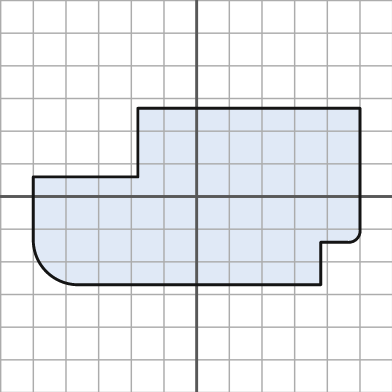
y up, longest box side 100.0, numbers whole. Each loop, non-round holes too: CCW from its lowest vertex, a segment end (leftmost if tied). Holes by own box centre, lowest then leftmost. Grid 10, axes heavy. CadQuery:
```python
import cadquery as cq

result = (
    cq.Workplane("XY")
    .moveTo(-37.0, -27.0)
    .lineTo(38.0, -27.0)
    .lineTo(38.0, -14.0)
    .lineTo(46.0, -14.0)
    .threePointArc((49.0, -13.0), (50.0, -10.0))
    .lineTo(50.0, 27.0)
    .lineTo(-18.0, 27.0)
    .lineTo(-18.0, 6.0)
    .lineTo(-50.0, 6.0)
    .lineTo(-50.0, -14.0)
    .threePointArc((-46.0, -23.0), (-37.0, -27.0))
    .close()
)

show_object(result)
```